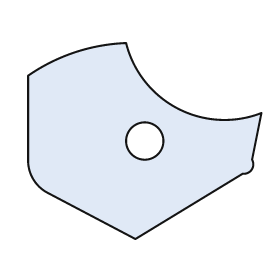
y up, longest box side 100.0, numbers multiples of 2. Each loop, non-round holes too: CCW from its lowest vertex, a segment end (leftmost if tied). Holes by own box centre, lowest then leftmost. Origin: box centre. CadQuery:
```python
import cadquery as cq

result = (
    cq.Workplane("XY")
    .moveTo(-4.0, -42.0)
    .lineTo(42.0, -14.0)
    .threePointArc((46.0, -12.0), (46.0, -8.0))
    .lineTo(50.0, 12.0)
    .threePointArc((14.0, 14.0), (-8.0, 42.0))
    .threePointArc((-30.0, 38.0), (-50.0, 28.0))
    .lineTo(-50.0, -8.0)
    .threePointArc((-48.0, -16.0), (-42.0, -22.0))
    .close()
    .moveTo(0.0, 0.0)
    .circle(8.0)
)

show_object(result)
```